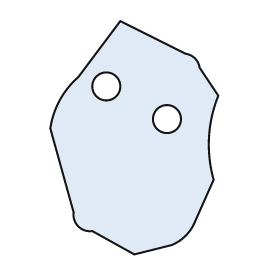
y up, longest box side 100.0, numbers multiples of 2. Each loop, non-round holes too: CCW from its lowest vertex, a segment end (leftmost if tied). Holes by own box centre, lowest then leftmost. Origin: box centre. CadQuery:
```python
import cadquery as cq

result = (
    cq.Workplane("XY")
    .moveTo(0.0, -50.0)
    .lineTo(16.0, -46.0)
    .threePointArc((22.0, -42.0), (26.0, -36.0))
    .lineTo(34.0, -18.0)
    .threePointArc((32.0, 0.0), (36.0, 18.0))
    .lineTo(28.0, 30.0)
    .threePointArc((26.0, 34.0), (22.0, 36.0))
    .lineTo(-6.0, 50.0)
    .lineTo(-24.0, 26.0)
    .threePointArc((-32.0, 16.0), (-36.0, 4.0))
    .lineTo(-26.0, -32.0)
    .threePointArc((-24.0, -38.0), (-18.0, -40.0))
    .close()
    .moveTo(14.0, 8.0)
    .circle(6.0)
    .moveTo(-12.0, 22.0)
    .circle(6.0)
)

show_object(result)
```